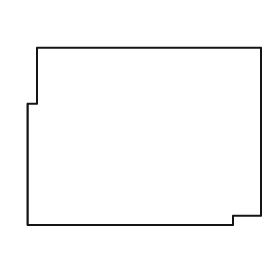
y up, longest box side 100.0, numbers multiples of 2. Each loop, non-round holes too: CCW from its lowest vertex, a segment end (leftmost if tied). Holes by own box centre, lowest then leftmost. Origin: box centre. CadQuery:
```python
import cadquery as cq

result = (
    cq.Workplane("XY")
    .moveTo(-50.0, -38.0)
    .lineTo(38.0, -38.0)
    .lineTo(38.0, -34.0)
    .lineTo(50.0, -34.0)
    .lineTo(50.0, 38.0)
    .lineTo(-46.0, 38.0)
    .lineTo(-46.0, 14.0)
    .lineTo(-50.0, 14.0)
    .close()
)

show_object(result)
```